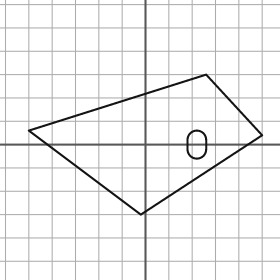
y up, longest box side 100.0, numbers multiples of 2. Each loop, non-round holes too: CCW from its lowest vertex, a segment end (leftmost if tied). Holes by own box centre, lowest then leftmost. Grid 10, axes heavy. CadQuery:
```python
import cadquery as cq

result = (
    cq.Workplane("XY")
    .moveTo(-2.0, -30.0)
    .lineTo(50.0, 4.0)
    .lineTo(26.0, 30.0)
    .lineTo(-50.0, 6.0)
    .close()
    .moveTo(18.0, -2.0)
    .threePointArc((22.0, -6.0), (26.0, -2.0))
    .lineTo(26.0, 2.0)
    .threePointArc((22.0, 6.0), (18.0, 2.0))
    .close()
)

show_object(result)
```